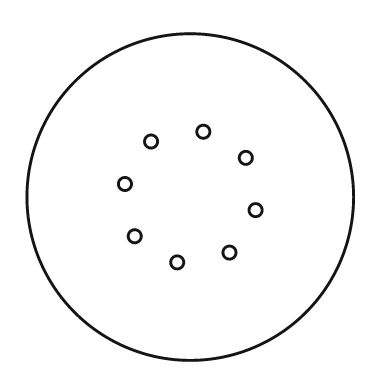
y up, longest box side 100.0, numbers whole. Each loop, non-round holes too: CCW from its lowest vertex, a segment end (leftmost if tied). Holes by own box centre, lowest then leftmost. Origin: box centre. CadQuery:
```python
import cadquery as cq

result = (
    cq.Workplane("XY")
    .moveTo(0.0, 0.0)
    .circle(50.0)
    .moveTo(-4.0, -20.0)
    .circle(2.0)
    .moveTo(12.0, -17.0)
    .circle(2.0)
    .moveTo(-17.0, -12.0)
    .circle(2.0)
    .moveTo(20.0, -4.0)
    .circle(2.0)
    .moveTo(-20.0, 4.0)
    .circle(2.0)
    .moveTo(17.0, 12.0)
    .circle(2.0)
    .moveTo(-12.0, 17.0)
    .circle(2.0)
    .moveTo(4.0, 20.0)
    .circle(2.0)
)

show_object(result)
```